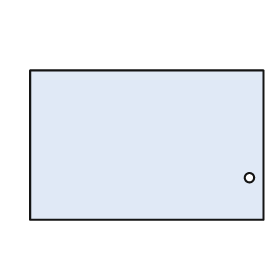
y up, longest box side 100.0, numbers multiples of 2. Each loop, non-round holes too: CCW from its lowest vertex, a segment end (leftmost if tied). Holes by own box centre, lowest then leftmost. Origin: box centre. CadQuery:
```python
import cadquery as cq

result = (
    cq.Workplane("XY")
    .moveTo(-50.0, -32.0)
    .lineTo(50.0, -32.0)
    .lineTo(50.0, 32.0)
    .lineTo(-50.0, 32.0)
    .close()
    .moveTo(44.0, -14.0)
    .circle(2.0)
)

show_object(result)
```